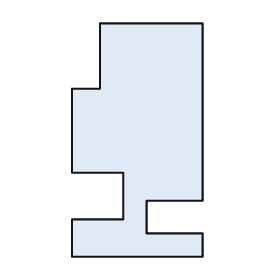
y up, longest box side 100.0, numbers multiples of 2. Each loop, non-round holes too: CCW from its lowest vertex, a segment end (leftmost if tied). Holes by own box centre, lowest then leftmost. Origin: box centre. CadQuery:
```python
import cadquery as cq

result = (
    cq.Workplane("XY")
    .moveTo(-28.0, -50.0)
    .lineTo(28.0, -50.0)
    .lineTo(28.0, -40.0)
    .lineTo(4.0, -40.0)
    .lineTo(4.0, -26.0)
    .lineTo(28.0, -26.0)
    .lineTo(28.0, 50.0)
    .lineTo(-16.0, 50.0)
    .lineTo(-16.0, 22.0)
    .lineTo(-28.0, 22.0)
    .lineTo(-28.0, -14.0)
    .lineTo(-6.0, -14.0)
    .lineTo(-6.0, -34.0)
    .lineTo(-28.0, -34.0)
    .close()
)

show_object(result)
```